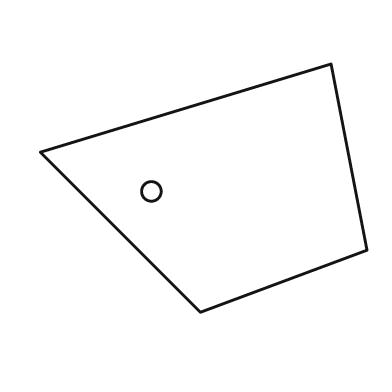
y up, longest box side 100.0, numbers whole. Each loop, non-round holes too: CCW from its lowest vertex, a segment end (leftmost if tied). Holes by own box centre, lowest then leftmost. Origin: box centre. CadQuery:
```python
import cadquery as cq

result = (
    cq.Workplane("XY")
    .moveTo(-1.0, -38.0)
    .lineTo(50.0, -19.0)
    .lineTo(39.0, 38.0)
    .lineTo(-50.0, 11.0)
    .close()
    .moveTo(-16.0, -1.0)
    .circle(3.0)
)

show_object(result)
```